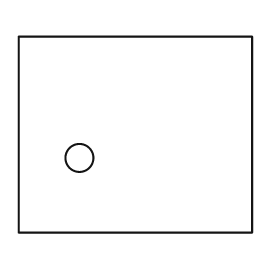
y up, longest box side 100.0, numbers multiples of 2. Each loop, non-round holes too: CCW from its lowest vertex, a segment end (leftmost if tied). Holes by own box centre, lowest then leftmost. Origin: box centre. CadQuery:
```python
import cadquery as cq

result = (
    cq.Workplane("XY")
    .moveTo(-50.0, -42.0)
    .lineTo(50.0, -42.0)
    .lineTo(50.0, 42.0)
    .lineTo(-50.0, 42.0)
    .close()
    .moveTo(-24.0, -10.0)
    .circle(6.0)
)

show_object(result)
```